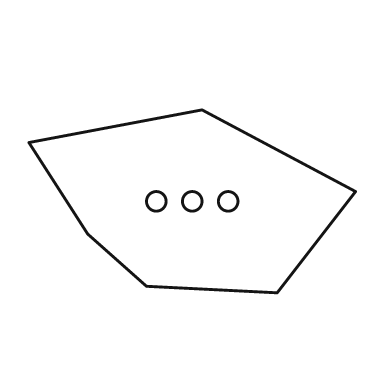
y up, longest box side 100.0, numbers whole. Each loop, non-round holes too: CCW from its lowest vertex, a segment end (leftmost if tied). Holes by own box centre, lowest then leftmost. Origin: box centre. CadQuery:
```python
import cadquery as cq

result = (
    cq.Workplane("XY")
    .moveTo(26.0, -28.0)
    .lineTo(50.0, 3.0)
    .lineTo(3.0, 28.0)
    .lineTo(-50.0, 18.0)
    .lineTo(-32.0, -10.0)
    .lineTo(-14.0, -26.0)
    .close()
    .moveTo(-11.0, 0.0)
    .circle(3.0)
    .moveTo(0.0, 0.0)
    .circle(3.0)
    .moveTo(11.0, 0.0)
    .circle(3.0)
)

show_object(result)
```